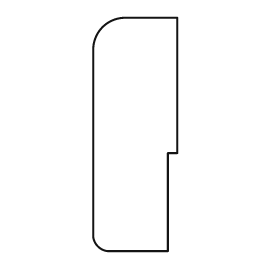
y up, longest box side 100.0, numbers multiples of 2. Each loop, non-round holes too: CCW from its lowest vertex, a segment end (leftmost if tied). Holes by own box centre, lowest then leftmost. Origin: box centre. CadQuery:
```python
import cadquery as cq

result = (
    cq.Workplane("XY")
    .moveTo(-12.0, -50.0)
    .lineTo(14.0, -50.0)
    .lineTo(14.0, -8.0)
    .lineTo(18.0, -8.0)
    .lineTo(18.0, 50.0)
    .lineTo(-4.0, 50.0)
    .threePointArc((-14.0, 46.0), (-18.0, 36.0))
    .lineTo(-18.0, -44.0)
    .threePointArc((-16.0, -48.0), (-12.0, -50.0))
    .close()
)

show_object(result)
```